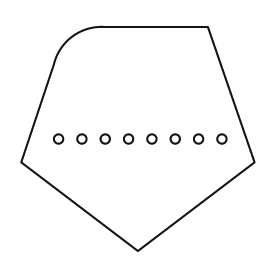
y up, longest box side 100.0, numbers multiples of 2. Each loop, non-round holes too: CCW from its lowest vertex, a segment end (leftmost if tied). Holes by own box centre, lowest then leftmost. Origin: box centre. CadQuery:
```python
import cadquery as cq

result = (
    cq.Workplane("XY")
    .moveTo(0.0, -48.0)
    .lineTo(50.0, -10.0)
    .lineTo(30.0, 48.0)
    .lineTo(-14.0, 48.0)
    .threePointArc((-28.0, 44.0), (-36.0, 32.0))
    .lineTo(-50.0, -10.0)
    .close()
    .moveTo(-34.0, 0.0)
    .circle(2.0)
    .moveTo(-24.0, 0.0)
    .circle(2.0)
    .moveTo(-14.0, 0.0)
    .circle(2.0)
    .moveTo(-4.0, 0.0)
    .circle(2.0)
    .moveTo(6.0, 0.0)
    .circle(2.0)
    .moveTo(16.0, 0.0)
    .circle(2.0)
    .moveTo(26.0, 0.0)
    .circle(2.0)
    .moveTo(36.0, 0.0)
    .circle(2.0)
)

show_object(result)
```